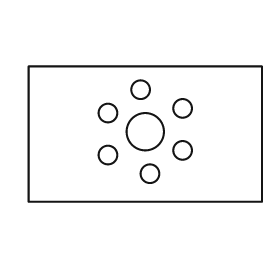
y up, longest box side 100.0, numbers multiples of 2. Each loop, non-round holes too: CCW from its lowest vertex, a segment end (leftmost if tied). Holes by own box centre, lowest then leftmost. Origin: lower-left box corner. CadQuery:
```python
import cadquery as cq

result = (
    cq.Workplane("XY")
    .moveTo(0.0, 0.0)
    .lineTo(100.0, 0.0)
    .lineTo(100.0, 58.0)
    .lineTo(0.0, 58.0)
    .close()
    .moveTo(52.0, 12.0)
    .circle(4.0)
    .moveTo(34.0, 20.0)
    .circle(4.0)
    .moveTo(66.0, 22.0)
    .circle(4.0)
    .moveTo(50.0, 30.0)
    .circle(8.0)
    .moveTo(34.0, 38.0)
    .circle(4.0)
    .moveTo(66.0, 40.0)
    .circle(4.0)
    .moveTo(48.0, 48.0)
    .circle(4.0)
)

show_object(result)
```